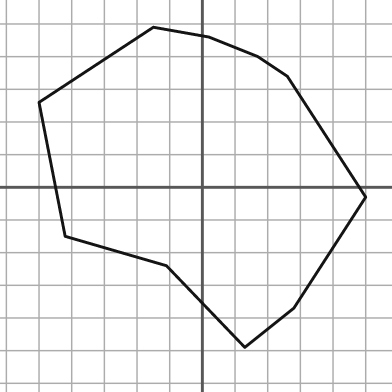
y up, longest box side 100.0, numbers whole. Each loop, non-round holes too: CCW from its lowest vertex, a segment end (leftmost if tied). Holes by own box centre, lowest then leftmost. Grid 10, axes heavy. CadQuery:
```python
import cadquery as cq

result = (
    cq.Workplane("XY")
    .moveTo(13.0, -49.0)
    .lineTo(28.0, -37.0)
    .lineTo(50.0, -3.0)
    .lineTo(26.0, 34.0)
    .lineTo(17.0, 40.0)
    .lineTo(2.0, 46.0)
    .lineTo(-15.0, 49.0)
    .lineTo(-50.0, 26.0)
    .lineTo(-42.0, -15.0)
    .lineTo(-11.0, -24.0)
    .close()
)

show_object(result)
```